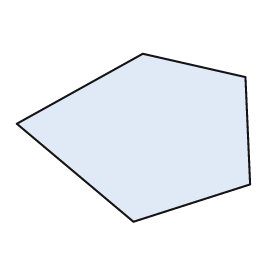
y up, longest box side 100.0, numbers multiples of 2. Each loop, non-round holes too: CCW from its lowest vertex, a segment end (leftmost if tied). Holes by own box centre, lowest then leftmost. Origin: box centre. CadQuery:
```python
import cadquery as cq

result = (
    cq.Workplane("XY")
    .moveTo(0.0, -36.0)
    .lineTo(50.0, -20.0)
    .lineTo(48.0, 26.0)
    .lineTo(4.0, 36.0)
    .lineTo(-50.0, 6.0)
    .close()
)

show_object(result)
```